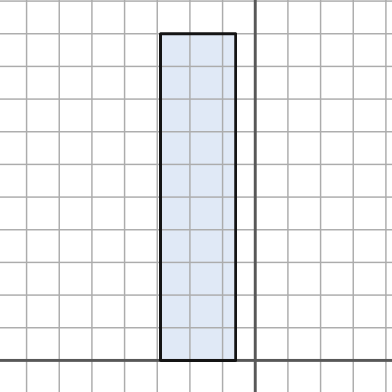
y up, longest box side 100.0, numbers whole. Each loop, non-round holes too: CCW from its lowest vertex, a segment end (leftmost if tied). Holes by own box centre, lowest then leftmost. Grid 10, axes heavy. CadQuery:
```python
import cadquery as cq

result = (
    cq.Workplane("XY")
    .moveTo(-29.0, 0.0)
    .lineTo(-6.0, 0.0)
    .lineTo(-6.0, 100.0)
    .lineTo(-29.0, 100.0)
    .close()
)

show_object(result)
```